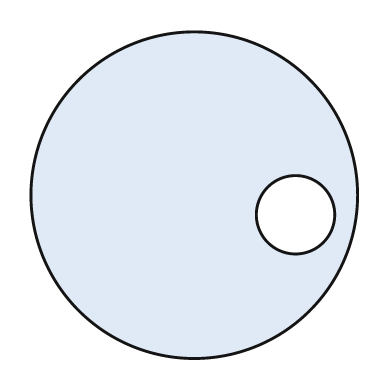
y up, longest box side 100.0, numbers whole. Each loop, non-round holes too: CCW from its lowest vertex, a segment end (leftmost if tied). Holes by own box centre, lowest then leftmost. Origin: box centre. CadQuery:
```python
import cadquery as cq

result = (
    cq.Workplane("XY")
    .moveTo(0.0, 0.0)
    .circle(50.0)
    .moveTo(31.0, -6.0)
    .circle(12.0)
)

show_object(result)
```